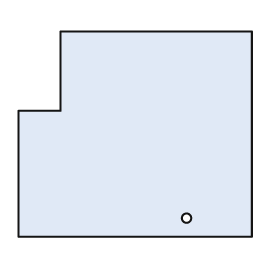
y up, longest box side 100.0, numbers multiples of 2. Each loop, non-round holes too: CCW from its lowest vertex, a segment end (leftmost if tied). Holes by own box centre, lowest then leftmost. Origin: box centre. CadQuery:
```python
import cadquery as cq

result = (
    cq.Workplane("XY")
    .moveTo(-50.0, -44.0)
    .lineTo(50.0, -44.0)
    .lineTo(50.0, 44.0)
    .lineTo(-32.0, 44.0)
    .lineTo(-32.0, 10.0)
    .lineTo(-50.0, 10.0)
    .close()
    .moveTo(22.0, -36.0)
    .circle(2.0)
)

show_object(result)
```